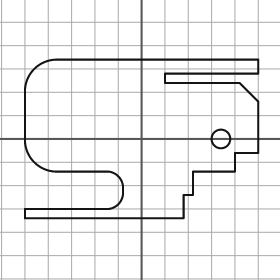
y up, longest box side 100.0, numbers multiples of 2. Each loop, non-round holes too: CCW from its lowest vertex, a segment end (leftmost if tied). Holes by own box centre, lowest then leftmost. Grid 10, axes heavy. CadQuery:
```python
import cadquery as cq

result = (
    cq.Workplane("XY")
    .moveTo(-50.0, -34.0)
    .lineTo(18.0, -34.0)
    .lineTo(18.0, -24.0)
    .lineTo(22.0, -24.0)
    .lineTo(22.0, -14.0)
    .lineTo(40.0, -14.0)
    .lineTo(40.0, -6.0)
    .lineTo(50.0, -6.0)
    .lineTo(50.0, 16.0)
    .lineTo(42.0, 24.0)
    .lineTo(10.0, 24.0)
    .lineTo(10.0, 28.0)
    .lineTo(50.0, 28.0)
    .lineTo(50.0, 34.0)
    .lineTo(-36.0, 34.0)
    .threePointArc((-46.0, 30.0), (-50.0, 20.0))
    .lineTo(-50.0, 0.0)
    .threePointArc((-46.0, -10.0), (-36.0, -14.0))
    .lineTo(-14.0, -14.0)
    .threePointArc((-10.0, -16.0), (-8.0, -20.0))
    .lineTo(-8.0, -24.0)
    .threePointArc((-10.0, -28.0), (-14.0, -30.0))
    .lineTo(-50.0, -30.0)
    .close()
    .moveTo(34.0, 0.0)
    .circle(4.0)
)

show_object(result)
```